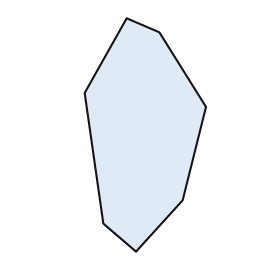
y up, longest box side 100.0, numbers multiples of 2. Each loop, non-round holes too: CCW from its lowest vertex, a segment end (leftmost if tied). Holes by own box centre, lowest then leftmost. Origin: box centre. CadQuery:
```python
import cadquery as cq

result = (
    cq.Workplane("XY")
    .moveTo(-4.0, -50.0)
    .lineTo(16.0, -28.0)
    .lineTo(26.0, 12.0)
    .lineTo(6.0, 44.0)
    .lineTo(-8.0, 50.0)
    .lineTo(-26.0, 18.0)
    .lineTo(-18.0, -38.0)
    .close()
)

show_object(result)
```